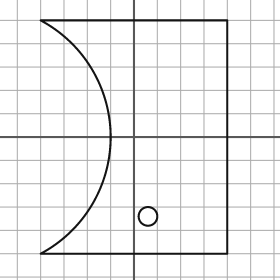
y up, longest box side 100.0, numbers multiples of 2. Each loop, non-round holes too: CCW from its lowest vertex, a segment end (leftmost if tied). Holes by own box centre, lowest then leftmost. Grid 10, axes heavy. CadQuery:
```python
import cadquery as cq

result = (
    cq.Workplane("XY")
    .moveTo(-40.0, -50.0)
    .lineTo(40.0, -50.0)
    .lineTo(40.0, 50.0)
    .lineTo(-40.0, 50.0)
    .threePointArc((-10.0, 0.0), (-40.0, -50.0))
    .close()
    .moveTo(6.0, -34.0)
    .circle(4.0)
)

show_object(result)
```